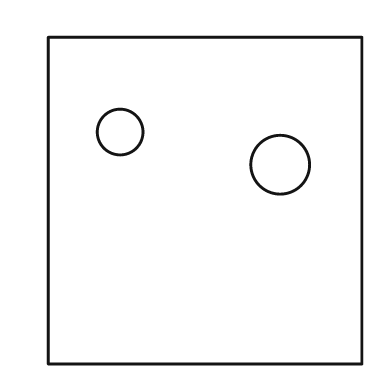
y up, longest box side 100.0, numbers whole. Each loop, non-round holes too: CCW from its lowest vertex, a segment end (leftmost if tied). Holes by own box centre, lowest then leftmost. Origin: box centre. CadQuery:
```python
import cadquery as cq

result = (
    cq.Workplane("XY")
    .moveTo(-48.0, -50.0)
    .lineTo(48.0, -50.0)
    .lineTo(48.0, 50.0)
    .lineTo(-48.0, 50.0)
    .close()
    .moveTo(23.0, 11.0)
    .circle(9.0)
    .moveTo(-26.0, 21.0)
    .circle(7.0)
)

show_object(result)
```